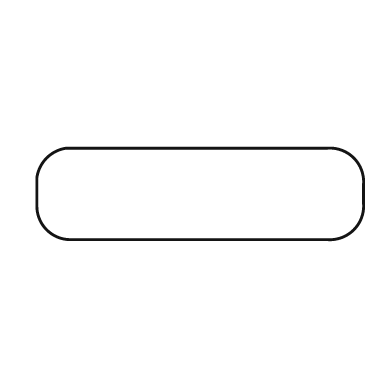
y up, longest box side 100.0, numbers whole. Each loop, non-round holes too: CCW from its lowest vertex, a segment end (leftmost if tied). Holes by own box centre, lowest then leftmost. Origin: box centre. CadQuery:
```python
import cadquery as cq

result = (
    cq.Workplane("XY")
    .moveTo(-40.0, -14.0)
    .lineTo(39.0, -14.0)
    .threePointArc((47.0, -11.0), (50.0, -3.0))
    .lineTo(50.0, 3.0)
    .threePointArc((47.0, 11.0), (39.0, 14.0))
    .lineTo(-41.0, 14.0)
    .threePointArc((-47.0, 11.0), (-50.0, 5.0))
    .lineTo(-50.0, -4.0)
    .threePointArc((-47.0, -11.0), (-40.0, -14.0))
    .close()
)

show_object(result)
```